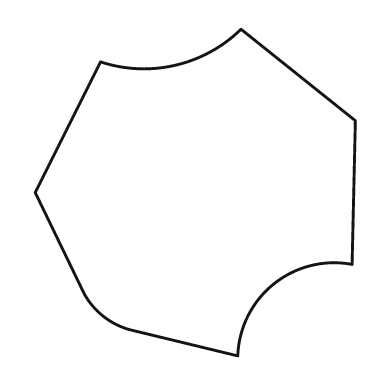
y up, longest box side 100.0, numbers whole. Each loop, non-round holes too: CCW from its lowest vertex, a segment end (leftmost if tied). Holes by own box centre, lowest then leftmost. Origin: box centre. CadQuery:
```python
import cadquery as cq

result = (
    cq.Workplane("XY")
    .moveTo(13.0, -50.0)
    .threePointArc((24.0, -28.0), (48.0, -22.0))
    .lineTo(49.0, 22.0)
    .lineTo(14.0, 50.0)
    .threePointArc((-6.0, 39.0), (-29.0, 40.0))
    .lineTo(-49.0, 0.0)
    .lineTo(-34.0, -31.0)
    .threePointArc((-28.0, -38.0), (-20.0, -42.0))
    .close()
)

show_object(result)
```